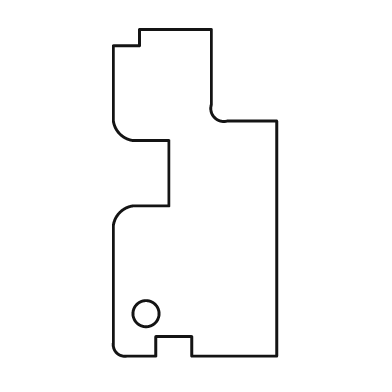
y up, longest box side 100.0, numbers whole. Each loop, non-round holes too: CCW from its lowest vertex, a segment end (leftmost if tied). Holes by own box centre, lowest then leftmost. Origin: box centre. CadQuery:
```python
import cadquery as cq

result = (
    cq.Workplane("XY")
    .moveTo(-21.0, -50.0)
    .lineTo(-12.0, -50.0)
    .lineTo(-12.0, -44.0)
    .lineTo(-1.0, -44.0)
    .lineTo(-1.0, -50.0)
    .lineTo(25.0, -50.0)
    .lineTo(25.0, 22.0)
    .lineTo(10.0, 22.0)
    .threePointArc((6.0, 23.0), (5.0, 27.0))
    .lineTo(5.0, 50.0)
    .lineTo(-17.0, 50.0)
    .lineTo(-17.0, 45.0)
    .lineTo(-25.0, 45.0)
    .lineTo(-25.0, 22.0)
    .threePointArc((-23.0, 18.0), (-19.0, 16.0))
    .lineTo(-8.0, 16.0)
    .lineTo(-8.0, -4.0)
    .lineTo(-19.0, -4.0)
    .threePointArc((-23.0, -6.0), (-25.0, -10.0))
    .lineTo(-25.0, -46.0)
    .threePointArc((-24.0, -49.0), (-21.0, -50.0))
    .close()
    .moveTo(-15.0, -37.0)
    .circle(4.0)
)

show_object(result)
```